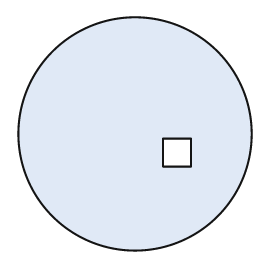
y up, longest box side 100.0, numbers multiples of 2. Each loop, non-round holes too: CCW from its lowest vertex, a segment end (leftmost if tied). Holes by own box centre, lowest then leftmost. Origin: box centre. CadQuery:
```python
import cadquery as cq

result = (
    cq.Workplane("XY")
    .moveTo(0.0, 0.0)
    .circle(50.0)
    .moveTo(12.0, -14.0)
    .lineTo(24.0, -14.0)
    .lineTo(24.0, -2.0)
    .lineTo(12.0, -2.0)
    .close()
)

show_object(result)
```